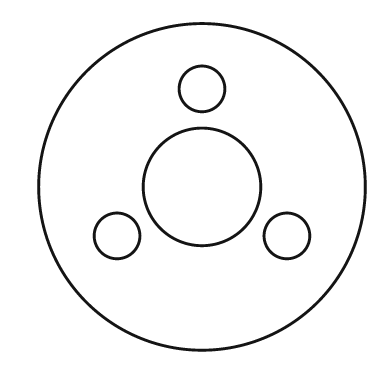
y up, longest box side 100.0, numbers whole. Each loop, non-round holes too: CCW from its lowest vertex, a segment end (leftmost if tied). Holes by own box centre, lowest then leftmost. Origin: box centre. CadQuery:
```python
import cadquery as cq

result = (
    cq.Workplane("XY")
    .moveTo(0.0, 0.0)
    .circle(50.0)
    .moveTo(-26.0, -15.0)
    .circle(7.0)
    .moveTo(26.0, -15.0)
    .circle(7.0)
    .moveTo(0.0, 0.0)
    .circle(18.0)
    .moveTo(0.0, 30.0)
    .circle(7.0)
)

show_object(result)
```